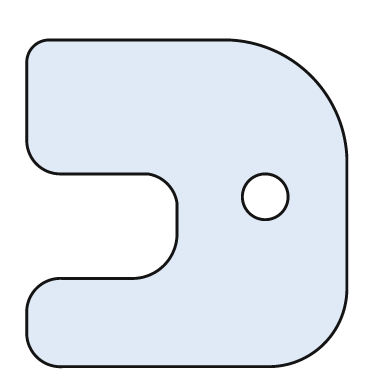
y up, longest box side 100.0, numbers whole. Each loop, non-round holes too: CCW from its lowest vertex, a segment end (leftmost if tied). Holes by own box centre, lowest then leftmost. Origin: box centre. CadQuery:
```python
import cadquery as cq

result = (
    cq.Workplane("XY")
    .moveTo(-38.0, -50.0)
    .lineTo(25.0, -50.0)
    .threePointArc((42.0, -43.0), (49.0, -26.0))
    .lineTo(49.0, 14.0)
    .threePointArc((38.0, 39.0), (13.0, 50.0))
    .lineTo(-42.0, 50.0)
    .threePointArc((-47.0, 48.0), (-49.0, 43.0))
    .lineTo(-49.0, 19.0)
    .threePointArc((-46.0, 12.0), (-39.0, 9.0))
    .lineTo(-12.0, 9.0)
    .threePointArc((-6.0, 6.0), (-3.0, 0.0))
    .lineTo(-3.0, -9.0)
    .threePointArc((-7.0, -19.0), (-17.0, -23.0))
    .lineTo(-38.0, -23.0)
    .threePointArc((-46.0, -26.0), (-49.0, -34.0))
    .lineTo(-49.0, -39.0)
    .threePointArc((-46.0, -47.0), (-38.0, -50.0))
    .close()
    .moveTo(24.0, 2.0)
    .circle(7.0)
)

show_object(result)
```